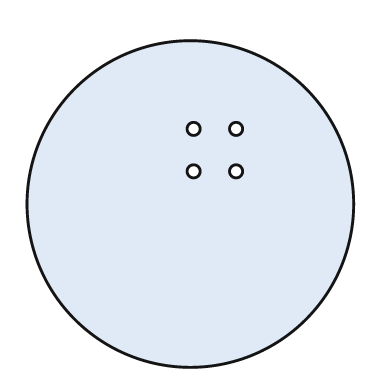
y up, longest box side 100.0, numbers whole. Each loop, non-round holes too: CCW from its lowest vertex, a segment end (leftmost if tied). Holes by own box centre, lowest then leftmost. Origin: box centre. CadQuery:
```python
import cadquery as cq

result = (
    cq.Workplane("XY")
    .moveTo(0.0, 0.0)
    .circle(50.0)
    .moveTo(1.0, 10.0)
    .circle(2.0)
    .moveTo(14.0, 10.0)
    .circle(2.0)
    .moveTo(1.0, 23.0)
    .circle(2.0)
    .moveTo(14.0, 23.0)
    .circle(2.0)
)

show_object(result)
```